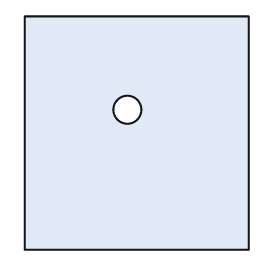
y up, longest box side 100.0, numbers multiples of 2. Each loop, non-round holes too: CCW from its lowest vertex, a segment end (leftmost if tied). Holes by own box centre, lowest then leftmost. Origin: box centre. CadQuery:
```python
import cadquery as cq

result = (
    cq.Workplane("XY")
    .moveTo(-48.0, -50.0)
    .lineTo(48.0, -50.0)
    .lineTo(48.0, 50.0)
    .lineTo(-48.0, 50.0)
    .close()
    .moveTo(-4.0, 10.0)
    .circle(6.0)
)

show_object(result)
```